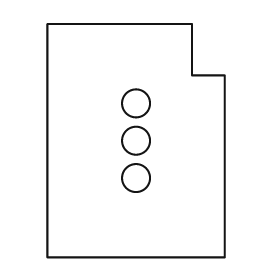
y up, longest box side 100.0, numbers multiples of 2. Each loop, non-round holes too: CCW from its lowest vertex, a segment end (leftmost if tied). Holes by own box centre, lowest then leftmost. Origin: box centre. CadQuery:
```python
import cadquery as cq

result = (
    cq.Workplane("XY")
    .moveTo(-38.0, -50.0)
    .lineTo(38.0, -50.0)
    .lineTo(38.0, 28.0)
    .lineTo(24.0, 28.0)
    .lineTo(24.0, 50.0)
    .lineTo(-38.0, 50.0)
    .close()
    .moveTo(0.0, -16.0)
    .circle(6.0)
    .moveTo(0.0, 0.0)
    .circle(6.0)
    .moveTo(0.0, 16.0)
    .circle(6.0)
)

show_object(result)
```